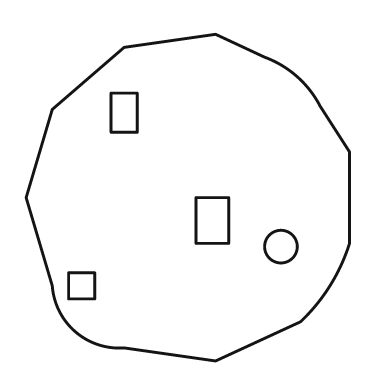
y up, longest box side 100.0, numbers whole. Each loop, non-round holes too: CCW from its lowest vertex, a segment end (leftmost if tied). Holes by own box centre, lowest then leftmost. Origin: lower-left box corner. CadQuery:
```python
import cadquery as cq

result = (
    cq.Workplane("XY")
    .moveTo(58.0, 0.0)
    .lineTo(84.0, 12.0)
    .threePointArc((93.0, 23.0), (99.0, 36.0))
    .lineTo(99.0, 64.0)
    .lineTo(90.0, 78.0)
    .threePointArc((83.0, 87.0), (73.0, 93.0))
    .lineTo(58.0, 100.0)
    .lineTo(30.0, 96.0)
    .lineTo(8.0, 77.0)
    .lineTo(0.0, 50.0)
    .lineTo(8.0, 23.0)
    .threePointArc((15.0, 9.0), (30.0, 4.0))
    .close()
    .moveTo(13.0, 19.0)
    .lineTo(21.0, 19.0)
    .lineTo(21.0, 27.0)
    .lineTo(13.0, 27.0)
    .close()
    .moveTo(78.0, 35.0)
    .circle(5.0)
    .moveTo(52.0, 36.0)
    .lineTo(62.0, 36.0)
    .lineTo(62.0, 50.0)
    .lineTo(52.0, 50.0)
    .close()
    .moveTo(26.0, 70.0)
    .lineTo(34.0, 70.0)
    .lineTo(34.0, 82.0)
    .lineTo(26.0, 82.0)
    .close()
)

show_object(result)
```